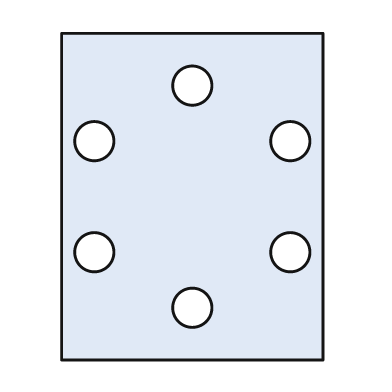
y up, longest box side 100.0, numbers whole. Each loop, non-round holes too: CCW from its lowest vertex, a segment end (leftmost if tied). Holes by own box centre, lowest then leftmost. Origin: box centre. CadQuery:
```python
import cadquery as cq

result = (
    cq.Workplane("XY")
    .moveTo(-40.0, -50.0)
    .lineTo(40.0, -50.0)
    .lineTo(40.0, 50.0)
    .lineTo(-40.0, 50.0)
    .close()
    .moveTo(0.0, -34.0)
    .circle(6.0)
    .moveTo(-30.0, -17.0)
    .circle(6.0)
    .moveTo(30.0, -17.0)
    .circle(6.0)
    .moveTo(-30.0, 17.0)
    .circle(6.0)
    .moveTo(30.0, 17.0)
    .circle(6.0)
    .moveTo(0.0, 34.0)
    .circle(6.0)
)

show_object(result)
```